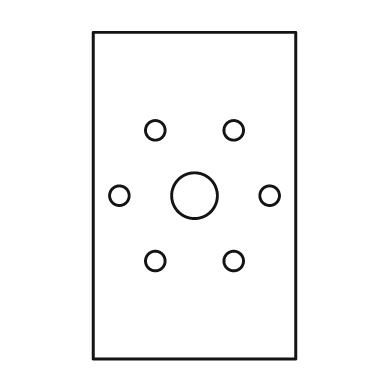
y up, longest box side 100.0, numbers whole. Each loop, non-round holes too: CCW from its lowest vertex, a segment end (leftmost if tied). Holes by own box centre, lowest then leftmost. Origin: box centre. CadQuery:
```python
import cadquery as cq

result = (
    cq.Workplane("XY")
    .moveTo(-31.0, -50.0)
    .lineTo(31.0, -50.0)
    .lineTo(31.0, 50.0)
    .lineTo(-31.0, 50.0)
    .close()
    .moveTo(-12.0, -20.0)
    .circle(3.0)
    .moveTo(12.0, -20.0)
    .circle(3.0)
    .moveTo(-23.0, 0.0)
    .circle(3.0)
    .moveTo(0.0, 0.0)
    .circle(7.0)
    .moveTo(23.0, 0.0)
    .circle(3.0)
    .moveTo(-12.0, 20.0)
    .circle(3.0)
    .moveTo(12.0, 20.0)
    .circle(3.0)
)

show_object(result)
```